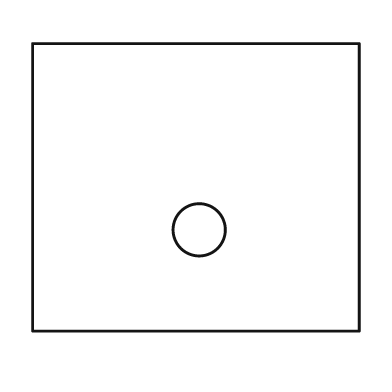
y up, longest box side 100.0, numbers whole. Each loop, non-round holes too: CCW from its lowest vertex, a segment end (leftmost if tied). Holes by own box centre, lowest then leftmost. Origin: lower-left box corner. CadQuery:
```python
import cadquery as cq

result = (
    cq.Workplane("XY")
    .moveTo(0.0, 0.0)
    .lineTo(100.0, 0.0)
    .lineTo(100.0, 88.0)
    .lineTo(0.0, 88.0)
    .close()
    .moveTo(51.0, 31.0)
    .circle(8.0)
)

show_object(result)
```